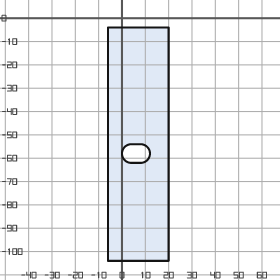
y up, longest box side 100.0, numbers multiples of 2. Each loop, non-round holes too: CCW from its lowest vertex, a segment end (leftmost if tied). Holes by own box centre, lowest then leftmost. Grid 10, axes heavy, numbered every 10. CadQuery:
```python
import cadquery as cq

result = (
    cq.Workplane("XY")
    .moveTo(-6.0, -104.0)
    .lineTo(20.0, -104.0)
    .lineTo(20.0, -4.0)
    .lineTo(-6.0, -4.0)
    .close()
    .moveTo(4.0, -62.0)
    .lineTo(8.0, -62.0)
    .threePointArc((12.0, -58.0), (8.0, -54.0))
    .lineTo(4.0, -54.0)
    .threePointArc((0.0, -58.0), (4.0, -62.0))
    .close()
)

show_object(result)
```